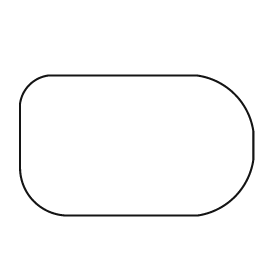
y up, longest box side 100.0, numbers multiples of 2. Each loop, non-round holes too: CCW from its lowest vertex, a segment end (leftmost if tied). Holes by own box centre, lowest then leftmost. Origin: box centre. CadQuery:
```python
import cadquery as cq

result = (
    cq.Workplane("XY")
    .moveTo(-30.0, -30.0)
    .lineTo(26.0, -30.0)
    .threePointArc((42.0, -22.0), (50.0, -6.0))
    .lineTo(50.0, 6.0)
    .threePointArc((42.0, 22.0), (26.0, 30.0))
    .lineTo(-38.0, 30.0)
    .threePointArc((-46.0, 26.0), (-50.0, 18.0))
    .lineTo(-50.0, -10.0)
    .threePointArc((-44.0, -24.0), (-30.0, -30.0))
    .close()
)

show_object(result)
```